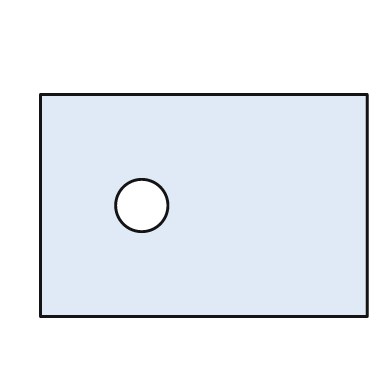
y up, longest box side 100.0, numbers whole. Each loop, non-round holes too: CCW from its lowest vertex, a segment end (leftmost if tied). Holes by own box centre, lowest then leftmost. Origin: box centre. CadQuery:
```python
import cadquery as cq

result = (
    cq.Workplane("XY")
    .moveTo(-50.0, -34.0)
    .lineTo(50.0, -34.0)
    .lineTo(50.0, 34.0)
    .lineTo(-50.0, 34.0)
    .close()
    .moveTo(-19.0, 0.0)
    .circle(8.0)
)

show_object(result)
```